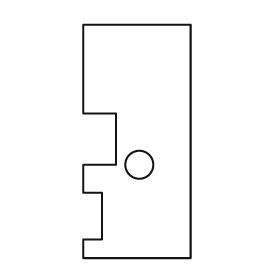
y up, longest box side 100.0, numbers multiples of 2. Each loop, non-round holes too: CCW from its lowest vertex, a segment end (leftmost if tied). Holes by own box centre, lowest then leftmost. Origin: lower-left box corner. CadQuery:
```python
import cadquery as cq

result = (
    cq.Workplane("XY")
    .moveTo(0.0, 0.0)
    .lineTo(46.0, 0.0)
    .lineTo(46.0, 100.0)
    .lineTo(0.0, 100.0)
    .lineTo(0.0, 62.0)
    .lineTo(14.0, 62.0)
    .lineTo(14.0, 40.0)
    .lineTo(0.0, 40.0)
    .lineTo(0.0, 28.0)
    .lineTo(8.0, 28.0)
    .lineTo(8.0, 8.0)
    .lineTo(0.0, 8.0)
    .close()
    .moveTo(24.0, 40.0)
    .circle(6.0)
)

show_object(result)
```